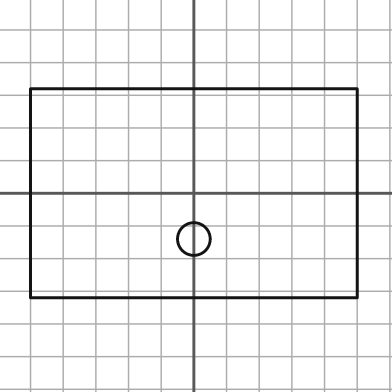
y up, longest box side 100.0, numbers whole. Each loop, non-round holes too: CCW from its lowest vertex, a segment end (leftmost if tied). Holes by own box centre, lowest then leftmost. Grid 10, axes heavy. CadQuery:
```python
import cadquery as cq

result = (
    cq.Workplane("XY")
    .moveTo(-50.0, -32.0)
    .lineTo(50.0, -32.0)
    .lineTo(50.0, 32.0)
    .lineTo(-50.0, 32.0)
    .close()
    .moveTo(0.0, -14.0)
    .circle(5.0)
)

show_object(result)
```